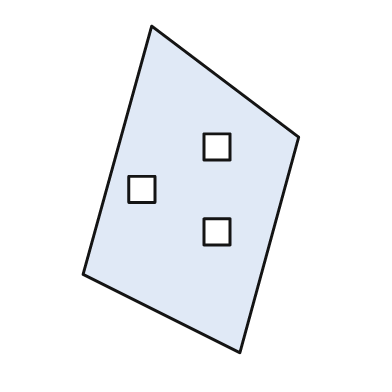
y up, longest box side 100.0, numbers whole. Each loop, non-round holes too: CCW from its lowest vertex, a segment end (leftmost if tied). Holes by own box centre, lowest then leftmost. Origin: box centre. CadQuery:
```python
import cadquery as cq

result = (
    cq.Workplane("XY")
    .moveTo(15.0, -50.0)
    .lineTo(33.0, 16.0)
    .lineTo(-12.0, 50.0)
    .lineTo(-33.0, -26.0)
    .close()
    .moveTo(4.0, -17.0)
    .lineTo(12.0, -17.0)
    .lineTo(12.0, -9.0)
    .lineTo(4.0, -9.0)
    .close()
    .moveTo(-19.0, -4.0)
    .lineTo(-11.0, -4.0)
    .lineTo(-11.0, 4.0)
    .lineTo(-19.0, 4.0)
    .close()
    .moveTo(4.0, 9.0)
    .lineTo(12.0, 9.0)
    .lineTo(12.0, 17.0)
    .lineTo(4.0, 17.0)
    .close()
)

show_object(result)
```